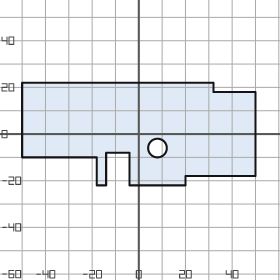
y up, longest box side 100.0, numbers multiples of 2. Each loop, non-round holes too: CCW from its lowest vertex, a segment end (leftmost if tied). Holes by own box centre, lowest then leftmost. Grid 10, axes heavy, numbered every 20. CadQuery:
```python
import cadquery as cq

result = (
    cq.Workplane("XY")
    .moveTo(-18.0, -22.0)
    .lineTo(-14.0, -22.0)
    .lineTo(-14.0, -8.0)
    .lineTo(-4.0, -8.0)
    .lineTo(-4.0, -22.0)
    .lineTo(20.0, -22.0)
    .lineTo(20.0, -18.0)
    .lineTo(50.0, -18.0)
    .lineTo(50.0, 18.0)
    .lineTo(32.0, 18.0)
    .lineTo(32.0, 22.0)
    .lineTo(-50.0, 22.0)
    .lineTo(-50.0, -10.0)
    .lineTo(-18.0, -10.0)
    .close()
    .moveTo(8.0, -6.0)
    .circle(4.0)
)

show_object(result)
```